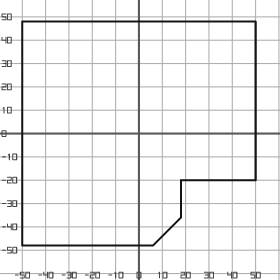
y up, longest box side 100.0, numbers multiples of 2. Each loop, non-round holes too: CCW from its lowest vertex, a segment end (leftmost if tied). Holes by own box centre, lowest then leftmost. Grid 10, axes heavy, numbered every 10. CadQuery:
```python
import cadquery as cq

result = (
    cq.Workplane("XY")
    .moveTo(-50.0, -48.0)
    .lineTo(6.0, -48.0)
    .lineTo(18.0, -36.0)
    .lineTo(18.0, -20.0)
    .lineTo(50.0, -20.0)
    .lineTo(50.0, 48.0)
    .lineTo(-50.0, 48.0)
    .close()
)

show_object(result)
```